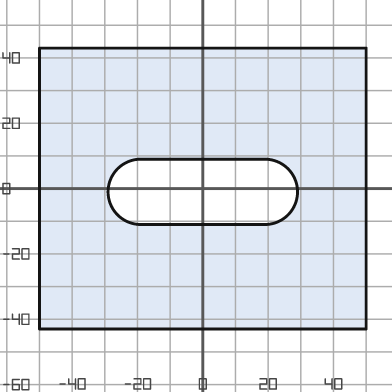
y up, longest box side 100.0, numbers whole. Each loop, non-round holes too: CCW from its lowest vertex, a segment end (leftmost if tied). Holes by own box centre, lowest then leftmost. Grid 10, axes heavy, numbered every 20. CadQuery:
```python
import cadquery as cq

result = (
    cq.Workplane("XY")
    .moveTo(-50.0, -43.0)
    .lineTo(50.0, -43.0)
    .lineTo(50.0, 43.0)
    .lineTo(-50.0, 43.0)
    .close()
    .moveTo(-19.0, -11.0)
    .lineTo(19.0, -11.0)
    .threePointArc((29.0, -1.0), (19.0, 9.0))
    .lineTo(-19.0, 9.0)
    .threePointArc((-29.0, -1.0), (-19.0, -11.0))
    .close()
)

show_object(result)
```